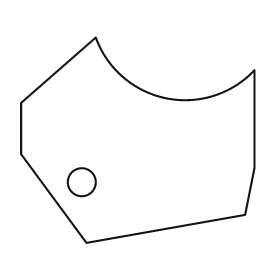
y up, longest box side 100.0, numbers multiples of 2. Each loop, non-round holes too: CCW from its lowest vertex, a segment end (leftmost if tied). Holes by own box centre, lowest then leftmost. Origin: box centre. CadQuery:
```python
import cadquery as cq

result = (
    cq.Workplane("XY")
    .moveTo(-22.0, -44.0)
    .lineTo(46.0, -32.0)
    .lineTo(50.0, -12.0)
    .lineTo(50.0, 30.0)
    .threePointArc((12.0, 18.0), (-18.0, 44.0))
    .lineTo(-50.0, 16.0)
    .lineTo(-50.0, -6.0)
    .close()
    .moveTo(-24.0, -18.0)
    .circle(6.0)
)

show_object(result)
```